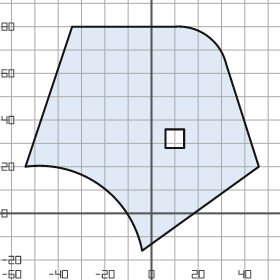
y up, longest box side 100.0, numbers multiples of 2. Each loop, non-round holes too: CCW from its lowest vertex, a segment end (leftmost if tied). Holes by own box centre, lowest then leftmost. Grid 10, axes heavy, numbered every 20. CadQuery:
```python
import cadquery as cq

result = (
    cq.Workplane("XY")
    .moveTo(-4.0, -16.0)
    .lineTo(46.0, 20.0)
    .lineTo(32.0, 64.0)
    .threePointArc((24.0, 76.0), (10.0, 80.0))
    .lineTo(-34.0, 80.0)
    .lineTo(-54.0, 20.0)
    .threePointArc((-22.0, 12.0), (-4.0, -16.0))
    .close()
    .moveTo(6.0, 28.0)
    .lineTo(14.0, 28.0)
    .lineTo(14.0, 36.0)
    .lineTo(6.0, 36.0)
    .close()
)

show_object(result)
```